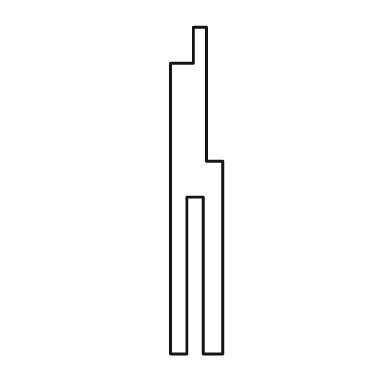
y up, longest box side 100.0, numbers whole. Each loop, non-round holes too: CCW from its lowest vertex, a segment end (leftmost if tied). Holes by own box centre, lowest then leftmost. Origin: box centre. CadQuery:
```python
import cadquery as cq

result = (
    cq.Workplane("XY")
    .moveTo(-8.0, -50.0)
    .lineTo(-3.0, -50.0)
    .lineTo(-3.0, -2.0)
    .lineTo(2.0, -2.0)
    .lineTo(2.0, -50.0)
    .lineTo(8.0, -50.0)
    .lineTo(8.0, 9.0)
    .lineTo(3.0, 9.0)
    .lineTo(3.0, 50.0)
    .lineTo(-1.0, 50.0)
    .lineTo(-1.0, 39.0)
    .lineTo(-8.0, 39.0)
    .close()
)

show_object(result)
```